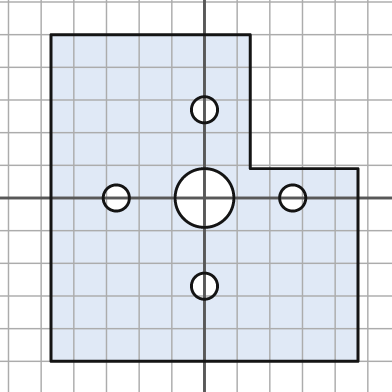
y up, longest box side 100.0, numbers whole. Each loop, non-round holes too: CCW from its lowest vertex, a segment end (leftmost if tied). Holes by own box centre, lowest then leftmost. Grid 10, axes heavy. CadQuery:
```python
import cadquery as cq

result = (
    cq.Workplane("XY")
    .moveTo(-47.0, -50.0)
    .lineTo(47.0, -50.0)
    .lineTo(47.0, 9.0)
    .lineTo(14.0, 9.0)
    .lineTo(14.0, 50.0)
    .lineTo(-47.0, 50.0)
    .close()
    .moveTo(0.0, -27.0)
    .circle(4.0)
    .moveTo(-27.0, 0.0)
    .circle(4.0)
    .moveTo(0.0, 0.0)
    .circle(9.0)
    .moveTo(27.0, 0.0)
    .circle(4.0)
    .moveTo(0.0, 27.0)
    .circle(4.0)
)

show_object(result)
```